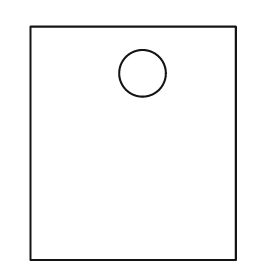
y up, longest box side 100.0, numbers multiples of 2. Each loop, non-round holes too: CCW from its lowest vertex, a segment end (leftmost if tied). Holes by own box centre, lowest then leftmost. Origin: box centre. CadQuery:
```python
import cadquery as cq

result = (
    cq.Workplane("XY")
    .moveTo(-44.0, -50.0)
    .lineTo(44.0, -50.0)
    .lineTo(44.0, 50.0)
    .lineTo(-44.0, 50.0)
    .close()
    .moveTo(4.0, 30.0)
    .circle(10.0)
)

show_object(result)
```